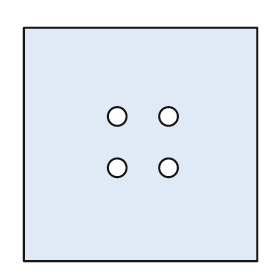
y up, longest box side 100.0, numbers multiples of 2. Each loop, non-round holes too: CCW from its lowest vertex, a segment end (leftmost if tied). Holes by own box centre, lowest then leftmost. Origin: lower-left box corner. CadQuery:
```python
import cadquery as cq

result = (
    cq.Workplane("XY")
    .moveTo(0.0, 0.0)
    .lineTo(100.0, 0.0)
    .lineTo(100.0, 100.0)
    .lineTo(0.0, 100.0)
    .close()
    .moveTo(40.0, 40.0)
    .circle(4.0)
    .moveTo(62.0, 40.0)
    .circle(4.0)
    .moveTo(40.0, 62.0)
    .circle(4.0)
    .moveTo(62.0, 62.0)
    .circle(4.0)
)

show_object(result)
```